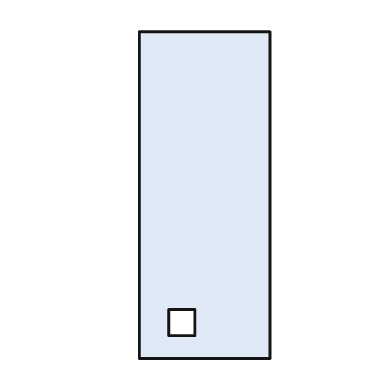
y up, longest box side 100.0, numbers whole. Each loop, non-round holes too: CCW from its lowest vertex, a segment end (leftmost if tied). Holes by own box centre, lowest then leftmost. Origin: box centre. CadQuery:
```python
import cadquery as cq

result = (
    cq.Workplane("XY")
    .moveTo(-20.0, -50.0)
    .lineTo(20.0, -50.0)
    .lineTo(20.0, 50.0)
    .lineTo(-20.0, 50.0)
    .close()
    .moveTo(-11.0, -43.0)
    .lineTo(-3.0, -43.0)
    .lineTo(-3.0, -35.0)
    .lineTo(-11.0, -35.0)
    .close()
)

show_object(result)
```